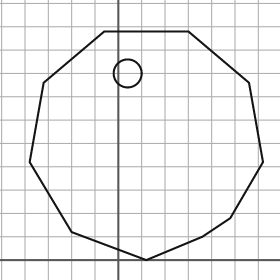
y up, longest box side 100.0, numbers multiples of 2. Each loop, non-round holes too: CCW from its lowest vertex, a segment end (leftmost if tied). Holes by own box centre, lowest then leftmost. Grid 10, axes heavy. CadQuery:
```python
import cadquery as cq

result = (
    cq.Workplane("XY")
    .moveTo(12.0, 0.0)
    .lineTo(36.0, 10.0)
    .lineTo(48.0, 18.0)
    .lineTo(62.0, 42.0)
    .lineTo(56.0, 76.0)
    .lineTo(30.0, 98.0)
    .lineTo(-6.0, 98.0)
    .lineTo(-32.0, 76.0)
    .lineTo(-38.0, 42.0)
    .lineTo(-20.0, 12.0)
    .close()
    .moveTo(4.0, 80.0)
    .circle(6.0)
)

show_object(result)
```